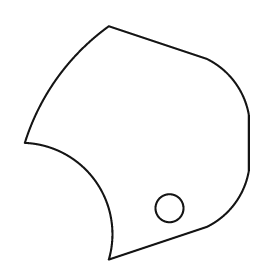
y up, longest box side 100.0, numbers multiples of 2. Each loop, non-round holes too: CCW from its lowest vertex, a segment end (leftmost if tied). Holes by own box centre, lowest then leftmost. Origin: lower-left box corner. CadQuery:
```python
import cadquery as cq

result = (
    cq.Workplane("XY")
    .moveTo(36.0, 0.0)
    .lineTo(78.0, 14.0)
    .threePointArc((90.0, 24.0), (96.0, 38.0))
    .lineTo(96.0, 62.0)
    .threePointArc((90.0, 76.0), (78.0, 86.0))
    .lineTo(36.0, 100.0)
    .threePointArc((14.0, 78.0), (0.0, 50.0))
    .threePointArc((30.0, 34.0), (36.0, 0.0))
    .close()
    .moveTo(62.0, 22.0)
    .circle(6.0)
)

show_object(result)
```